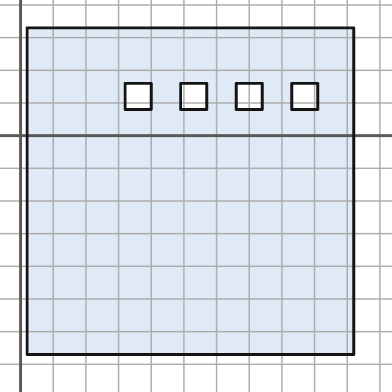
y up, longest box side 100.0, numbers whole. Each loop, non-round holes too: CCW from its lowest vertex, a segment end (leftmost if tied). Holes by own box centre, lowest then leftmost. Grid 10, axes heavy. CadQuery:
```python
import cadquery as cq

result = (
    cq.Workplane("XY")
    .moveTo(2.0, -67.0)
    .lineTo(102.0, -67.0)
    .lineTo(102.0, 33.0)
    .lineTo(2.0, 33.0)
    .close()
    .moveTo(32.0, 8.0)
    .lineTo(40.0, 8.0)
    .lineTo(40.0, 16.0)
    .lineTo(32.0, 16.0)
    .close()
    .moveTo(49.0, 8.0)
    .lineTo(57.0, 8.0)
    .lineTo(57.0, 16.0)
    .lineTo(49.0, 16.0)
    .close()
    .moveTo(66.0, 8.0)
    .lineTo(74.0, 8.0)
    .lineTo(74.0, 16.0)
    .lineTo(66.0, 16.0)
    .close()
    .moveTo(83.0, 8.0)
    .lineTo(91.0, 8.0)
    .lineTo(91.0, 16.0)
    .lineTo(83.0, 16.0)
    .close()
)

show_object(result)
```